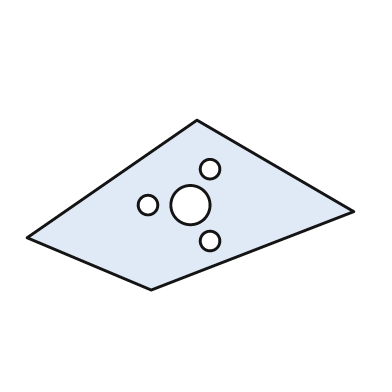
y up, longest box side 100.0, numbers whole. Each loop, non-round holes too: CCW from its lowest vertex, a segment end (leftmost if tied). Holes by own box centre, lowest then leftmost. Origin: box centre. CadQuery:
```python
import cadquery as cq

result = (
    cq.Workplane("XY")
    .moveTo(-12.0, -26.0)
    .lineTo(50.0, -2.0)
    .lineTo(2.0, 26.0)
    .lineTo(-50.0, -10.0)
    .close()
    .moveTo(6.0, -11.0)
    .circle(3.0)
    .moveTo(-13.0, 0.0)
    .circle(3.0)
    .moveTo(0.0, 0.0)
    .circle(6.0)
    .moveTo(6.0, 11.0)
    .circle(3.0)
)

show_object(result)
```